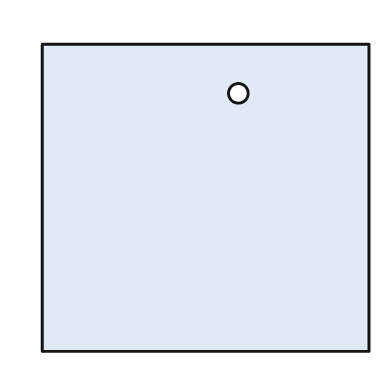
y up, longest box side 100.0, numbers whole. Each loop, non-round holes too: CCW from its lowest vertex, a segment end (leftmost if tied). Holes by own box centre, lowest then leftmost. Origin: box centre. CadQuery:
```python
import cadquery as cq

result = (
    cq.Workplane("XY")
    .moveTo(-50.0, -47.0)
    .lineTo(50.0, -47.0)
    .lineTo(50.0, 47.0)
    .lineTo(-50.0, 47.0)
    .close()
    .moveTo(10.0, 32.0)
    .circle(3.0)
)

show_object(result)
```